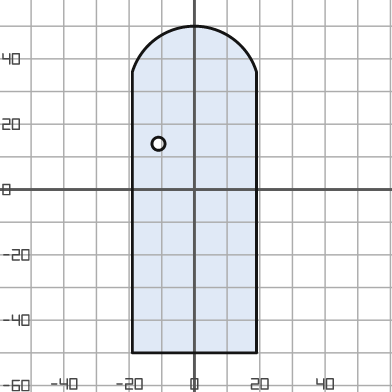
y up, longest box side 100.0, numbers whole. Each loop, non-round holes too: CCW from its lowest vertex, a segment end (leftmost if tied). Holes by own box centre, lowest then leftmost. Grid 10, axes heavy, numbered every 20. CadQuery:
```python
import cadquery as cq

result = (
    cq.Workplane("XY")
    .moveTo(-19.0, -50.0)
    .lineTo(19.0, -50.0)
    .lineTo(19.0, 36.0)
    .threePointArc((0.0, 50.0), (-19.0, 36.0))
    .close()
    .moveTo(-11.0, 14.0)
    .circle(2.0)
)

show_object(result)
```